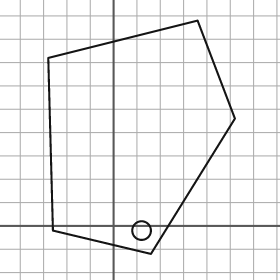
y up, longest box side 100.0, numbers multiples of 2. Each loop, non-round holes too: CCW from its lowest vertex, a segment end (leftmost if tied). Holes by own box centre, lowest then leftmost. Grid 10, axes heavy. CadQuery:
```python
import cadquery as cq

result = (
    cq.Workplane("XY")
    .moveTo(16.0, -12.0)
    .lineTo(52.0, 46.0)
    .lineTo(36.0, 88.0)
    .lineTo(-28.0, 72.0)
    .lineTo(-26.0, -2.0)
    .close()
    .moveTo(12.0, -2.0)
    .circle(4.0)
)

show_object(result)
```